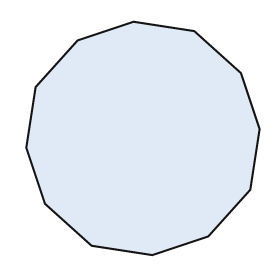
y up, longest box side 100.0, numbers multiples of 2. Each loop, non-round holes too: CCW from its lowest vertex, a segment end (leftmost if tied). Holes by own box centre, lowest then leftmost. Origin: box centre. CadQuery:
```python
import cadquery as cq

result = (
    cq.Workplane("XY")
    .moveTo(4.0, -50.0)
    .lineTo(28.0, -42.0)
    .lineTo(46.0, -22.0)
    .lineTo(50.0, 4.0)
    .lineTo(42.0, 28.0)
    .lineTo(22.0, 46.0)
    .lineTo(-4.0, 50.0)
    .lineTo(-28.0, 42.0)
    .lineTo(-46.0, 22.0)
    .lineTo(-50.0, -4.0)
    .lineTo(-42.0, -28.0)
    .lineTo(-22.0, -46.0)
    .close()
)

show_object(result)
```